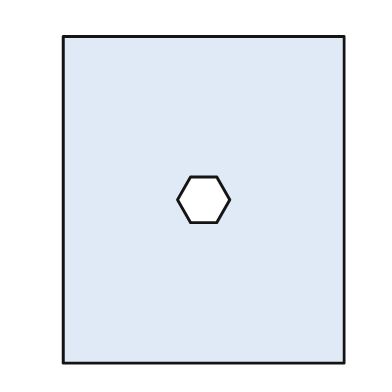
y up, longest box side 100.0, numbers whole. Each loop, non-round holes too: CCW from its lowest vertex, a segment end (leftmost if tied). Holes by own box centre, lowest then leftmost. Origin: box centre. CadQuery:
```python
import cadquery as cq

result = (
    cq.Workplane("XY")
    .moveTo(-43.0, -50.0)
    .lineTo(43.0, -50.0)
    .lineTo(43.0, 50.0)
    .lineTo(-43.0, 50.0)
    .close()
    .moveTo(-4.0, -7.0)
    .lineTo(4.0, -7.0)
    .lineTo(8.0, 0.0)
    .lineTo(4.0, 7.0)
    .lineTo(-4.0, 7.0)
    .lineTo(-8.0, 0.0)
    .close()
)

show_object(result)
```